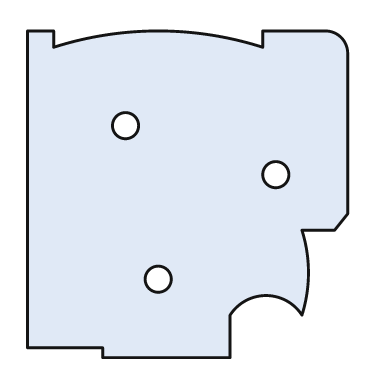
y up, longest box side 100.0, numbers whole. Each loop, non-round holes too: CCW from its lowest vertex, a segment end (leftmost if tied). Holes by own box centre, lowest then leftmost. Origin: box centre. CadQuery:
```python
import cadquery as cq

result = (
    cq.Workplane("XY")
    .moveTo(-26.0, -50.0)
    .lineTo(13.0, -50.0)
    .lineTo(13.0, -37.0)
    .threePointArc((24.0, -31.0), (35.0, -37.0))
    .threePointArc((37.0, -24.0), (35.0, -11.0))
    .lineTo(45.0, -11.0)
    .lineTo(49.0, -6.0)
    .lineTo(49.0, 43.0)
    .threePointArc((47.0, 48.0), (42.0, 50.0))
    .lineTo(23.0, 50.0)
    .lineTo(23.0, 45.0)
    .threePointArc((-9.0, 50.0), (-41.0, 45.0))
    .lineTo(-41.0, 50.0)
    .lineTo(-49.0, 50.0)
    .lineTo(-49.0, -47.0)
    .lineTo(-26.0, -47.0)
    .close()
    .moveTo(-9.0, -26.0)
    .circle(4.0)
    .moveTo(27.0, 6.0)
    .circle(4.0)
    .moveTo(-19.0, 21.0)
    .circle(4.0)
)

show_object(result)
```